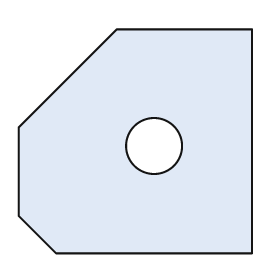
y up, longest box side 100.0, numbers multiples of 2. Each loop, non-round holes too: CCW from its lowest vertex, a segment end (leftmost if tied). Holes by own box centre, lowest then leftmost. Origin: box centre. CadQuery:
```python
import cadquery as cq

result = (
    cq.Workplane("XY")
    .moveTo(-34.0, -48.0)
    .lineTo(50.0, -48.0)
    .lineTo(50.0, 48.0)
    .lineTo(-8.0, 48.0)
    .lineTo(-50.0, 6.0)
    .lineTo(-50.0, -32.0)
    .close()
    .moveTo(8.0, -2.0)
    .circle(12.0)
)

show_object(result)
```